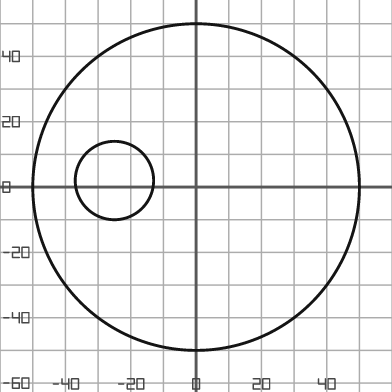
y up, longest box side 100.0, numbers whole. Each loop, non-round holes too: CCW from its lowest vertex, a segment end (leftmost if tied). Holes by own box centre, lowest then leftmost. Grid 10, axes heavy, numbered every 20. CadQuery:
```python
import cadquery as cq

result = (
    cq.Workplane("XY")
    .moveTo(0.0, 0.0)
    .circle(50.0)
    .moveTo(-25.0, 2.0)
    .circle(12.0)
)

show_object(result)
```